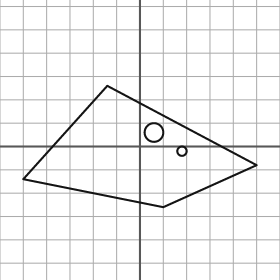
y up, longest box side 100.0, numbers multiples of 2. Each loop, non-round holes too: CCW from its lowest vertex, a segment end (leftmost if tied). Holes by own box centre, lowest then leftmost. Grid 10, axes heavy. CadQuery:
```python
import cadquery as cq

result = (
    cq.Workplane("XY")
    .moveTo(10.0, -26.0)
    .lineTo(50.0, -8.0)
    .lineTo(-14.0, 26.0)
    .lineTo(-50.0, -14.0)
    .close()
    .moveTo(18.0, -2.0)
    .circle(2.0)
    .moveTo(6.0, 6.0)
    .circle(4.0)
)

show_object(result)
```